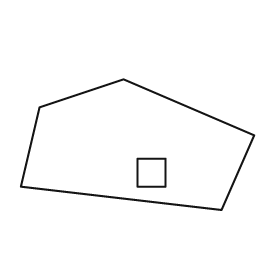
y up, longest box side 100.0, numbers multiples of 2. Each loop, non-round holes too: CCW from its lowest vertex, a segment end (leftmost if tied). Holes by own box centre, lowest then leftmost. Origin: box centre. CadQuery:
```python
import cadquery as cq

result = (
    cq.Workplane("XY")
    .moveTo(36.0, -28.0)
    .lineTo(50.0, 4.0)
    .lineTo(-6.0, 28.0)
    .lineTo(-42.0, 16.0)
    .lineTo(-50.0, -18.0)
    .close()
    .moveTo(0.0, -18.0)
    .lineTo(12.0, -18.0)
    .lineTo(12.0, -6.0)
    .lineTo(0.0, -6.0)
    .close()
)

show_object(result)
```